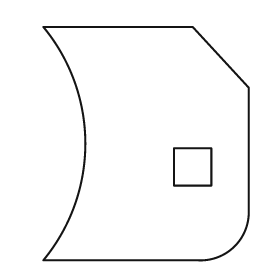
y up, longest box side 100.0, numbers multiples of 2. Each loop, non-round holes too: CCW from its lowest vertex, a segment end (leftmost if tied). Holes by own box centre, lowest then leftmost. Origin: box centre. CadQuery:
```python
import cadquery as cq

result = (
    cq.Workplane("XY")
    .moveTo(-44.0, -50.0)
    .lineTo(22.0, -50.0)
    .threePointArc((38.0, -44.0), (44.0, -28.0))
    .lineTo(44.0, 24.0)
    .lineTo(20.0, 50.0)
    .lineTo(-44.0, 50.0)
    .threePointArc((-26.0, 0.0), (-44.0, -50.0))
    .close()
    .moveTo(12.0, -18.0)
    .lineTo(28.0, -18.0)
    .lineTo(28.0, -2.0)
    .lineTo(12.0, -2.0)
    .close()
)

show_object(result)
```